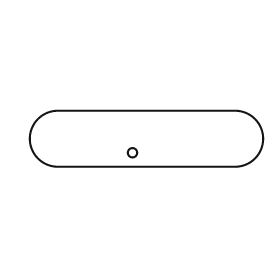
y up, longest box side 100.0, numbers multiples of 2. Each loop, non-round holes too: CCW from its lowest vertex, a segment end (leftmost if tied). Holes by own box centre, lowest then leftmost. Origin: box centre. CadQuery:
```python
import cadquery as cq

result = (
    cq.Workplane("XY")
    .moveTo(-38.0, -12.0)
    .lineTo(38.0, -12.0)
    .threePointArc((50.0, 0.0), (38.0, 12.0))
    .lineTo(-38.0, 12.0)
    .threePointArc((-50.0, 0.0), (-38.0, -12.0))
    .close()
    .moveTo(-6.0, -6.0)
    .circle(2.0)
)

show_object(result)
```